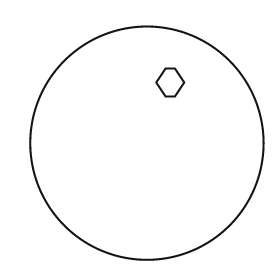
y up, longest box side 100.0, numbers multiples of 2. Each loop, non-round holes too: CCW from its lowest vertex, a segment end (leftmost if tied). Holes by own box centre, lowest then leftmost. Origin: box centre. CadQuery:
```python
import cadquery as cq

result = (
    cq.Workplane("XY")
    .moveTo(0.0, 0.0)
    .circle(50.0)
    .moveTo(8.0, 20.0)
    .lineTo(12.0, 20.0)
    .lineTo(16.0, 26.0)
    .lineTo(12.0, 32.0)
    .lineTo(8.0, 32.0)
    .lineTo(4.0, 26.0)
    .close()
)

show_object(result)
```